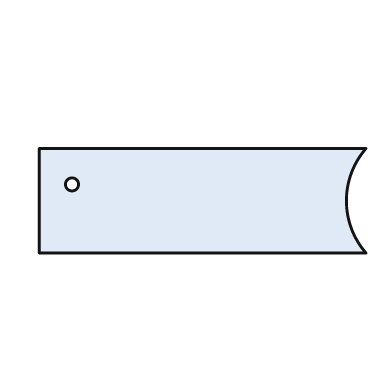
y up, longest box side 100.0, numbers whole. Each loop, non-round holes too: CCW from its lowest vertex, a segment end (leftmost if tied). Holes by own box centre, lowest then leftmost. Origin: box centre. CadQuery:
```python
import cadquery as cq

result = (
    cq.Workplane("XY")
    .moveTo(-50.0, -16.0)
    .lineTo(50.0, -16.0)
    .threePointArc((44.0, 0.0), (50.0, 16.0))
    .lineTo(-50.0, 16.0)
    .close()
    .moveTo(-40.0, 5.0)
    .circle(2.0)
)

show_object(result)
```